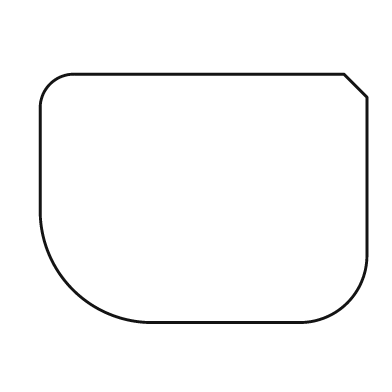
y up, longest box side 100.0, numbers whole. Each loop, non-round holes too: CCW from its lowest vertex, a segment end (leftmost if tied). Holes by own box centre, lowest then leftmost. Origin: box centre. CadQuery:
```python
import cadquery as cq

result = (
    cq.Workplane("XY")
    .moveTo(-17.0, -38.0)
    .lineTo(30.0, -38.0)
    .threePointArc((44.0, -32.0), (50.0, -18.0))
    .lineTo(50.0, 31.0)
    .lineTo(43.0, 38.0)
    .lineTo(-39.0, 38.0)
    .threePointArc((-47.0, 35.0), (-50.0, 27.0))
    .lineTo(-50.0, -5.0)
    .threePointArc((-40.0, -28.0), (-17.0, -38.0))
    .close()
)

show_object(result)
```